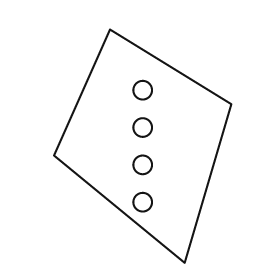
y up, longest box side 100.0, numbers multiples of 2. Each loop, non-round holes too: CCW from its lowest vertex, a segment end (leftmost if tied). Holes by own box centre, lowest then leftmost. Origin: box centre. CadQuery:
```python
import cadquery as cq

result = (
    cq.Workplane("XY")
    .moveTo(18.0, -50.0)
    .lineTo(38.0, 18.0)
    .lineTo(-14.0, 50.0)
    .lineTo(-38.0, -4.0)
    .close()
    .moveTo(0.0, -24.0)
    .circle(4.0)
    .moveTo(0.0, -8.0)
    .circle(4.0)
    .moveTo(0.0, 8.0)
    .circle(4.0)
    .moveTo(0.0, 24.0)
    .circle(4.0)
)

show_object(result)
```